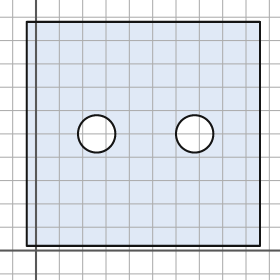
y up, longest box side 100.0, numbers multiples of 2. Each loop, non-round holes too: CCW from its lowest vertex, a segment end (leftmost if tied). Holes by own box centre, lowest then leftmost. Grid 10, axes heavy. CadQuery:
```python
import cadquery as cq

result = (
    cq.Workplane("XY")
    .moveTo(-4.0, 2.0)
    .lineTo(96.0, 2.0)
    .lineTo(96.0, 98.0)
    .lineTo(-4.0, 98.0)
    .close()
    .moveTo(26.0, 50.0)
    .circle(8.0)
    .moveTo(68.0, 50.0)
    .circle(8.0)
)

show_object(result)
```